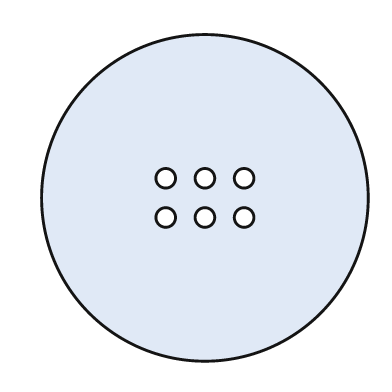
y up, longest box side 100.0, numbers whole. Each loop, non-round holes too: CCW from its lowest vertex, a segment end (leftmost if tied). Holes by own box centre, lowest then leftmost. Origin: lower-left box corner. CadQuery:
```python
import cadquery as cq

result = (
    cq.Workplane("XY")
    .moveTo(50.0, 50.0)
    .circle(50.0)
    .moveTo(38.0, 44.0)
    .circle(3.0)
    .moveTo(50.0, 44.0)
    .circle(3.0)
    .moveTo(62.0, 44.0)
    .circle(3.0)
    .moveTo(38.0, 56.0)
    .circle(3.0)
    .moveTo(50.0, 56.0)
    .circle(3.0)
    .moveTo(62.0, 56.0)
    .circle(3.0)
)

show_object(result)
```